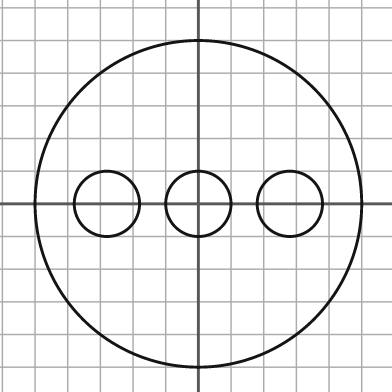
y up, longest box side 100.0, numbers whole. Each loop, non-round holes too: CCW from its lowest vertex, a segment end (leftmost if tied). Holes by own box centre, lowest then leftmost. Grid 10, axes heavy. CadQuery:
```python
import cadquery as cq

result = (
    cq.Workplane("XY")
    .moveTo(0.0, 0.0)
    .circle(50.0)
    .moveTo(-28.0, 0.0)
    .circle(10.0)
    .moveTo(0.0, 0.0)
    .circle(10.0)
    .moveTo(28.0, 0.0)
    .circle(10.0)
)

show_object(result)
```